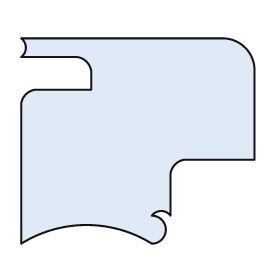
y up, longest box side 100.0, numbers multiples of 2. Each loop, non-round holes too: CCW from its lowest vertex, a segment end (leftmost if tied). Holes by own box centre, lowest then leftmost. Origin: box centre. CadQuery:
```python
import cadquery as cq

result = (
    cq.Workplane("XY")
    .moveTo(-50.0, -44.0)
    .threePointArc((-22.0, -36.0), (6.0, -44.0))
    .threePointArc((12.0, -38.0), (6.0, -32.0))
    .threePointArc((10.0, -30.0), (14.0, -32.0))
    .lineTo(14.0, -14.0)
    .threePointArc((16.0, -10.0), (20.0, -8.0))
    .lineTo(50.0, -8.0)
    .lineTo(50.0, 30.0)
    .threePointArc((46.0, 40.0), (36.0, 44.0))
    .lineTo(-50.0, 44.0)
    .threePointArc((-48.0, 40.0), (-50.0, 36.0))
    .lineTo(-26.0, 36.0)
    .threePointArc((-22.0, 34.0), (-20.0, 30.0))
    .lineTo(-20.0, 22.0)
    .lineTo(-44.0, 22.0)
    .threePointArc((-48.0, 20.0), (-50.0, 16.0))
    .close()
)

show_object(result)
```